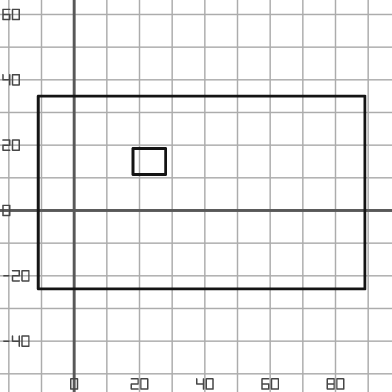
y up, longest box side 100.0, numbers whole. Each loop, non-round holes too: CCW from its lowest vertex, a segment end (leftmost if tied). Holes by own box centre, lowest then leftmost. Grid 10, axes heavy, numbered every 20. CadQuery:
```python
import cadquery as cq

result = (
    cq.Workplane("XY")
    .moveTo(-11.0, -24.0)
    .lineTo(89.0, -24.0)
    .lineTo(89.0, 35.0)
    .lineTo(-11.0, 35.0)
    .close()
    .moveTo(18.0, 11.0)
    .lineTo(28.0, 11.0)
    .lineTo(28.0, 19.0)
    .lineTo(18.0, 19.0)
    .close()
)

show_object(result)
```